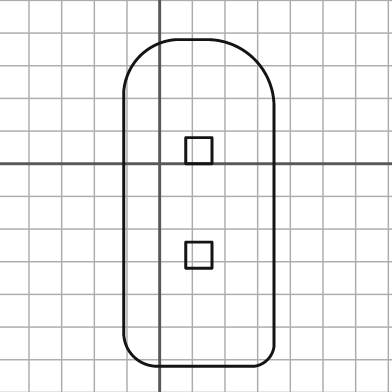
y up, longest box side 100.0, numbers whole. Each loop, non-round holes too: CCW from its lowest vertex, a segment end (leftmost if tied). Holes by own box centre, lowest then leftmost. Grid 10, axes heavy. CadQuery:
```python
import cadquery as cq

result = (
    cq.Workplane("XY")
    .moveTo(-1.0, -62.0)
    .lineTo(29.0, -62.0)
    .threePointArc((33.0, -60.0), (35.0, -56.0))
    .lineTo(35.0, 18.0)
    .threePointArc((29.0, 32.0), (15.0, 38.0))
    .lineTo(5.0, 38.0)
    .threePointArc((-6.0, 33.0), (-11.0, 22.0))
    .lineTo(-11.0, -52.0)
    .threePointArc((-8.0, -59.0), (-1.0, -62.0))
    .close()
    .moveTo(8.0, -32.0)
    .lineTo(16.0, -32.0)
    .lineTo(16.0, -24.0)
    .lineTo(8.0, -24.0)
    .close()
    .moveTo(8.0, 0.0)
    .lineTo(16.0, 0.0)
    .lineTo(16.0, 8.0)
    .lineTo(8.0, 8.0)
    .close()
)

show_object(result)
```